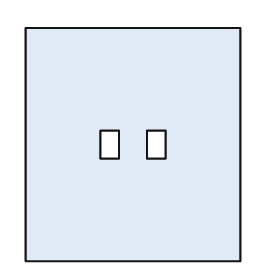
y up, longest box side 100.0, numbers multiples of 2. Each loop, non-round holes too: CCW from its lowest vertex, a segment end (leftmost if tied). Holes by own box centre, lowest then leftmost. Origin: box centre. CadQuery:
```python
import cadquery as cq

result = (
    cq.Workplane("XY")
    .moveTo(-46.0, -50.0)
    .lineTo(46.0, -50.0)
    .lineTo(46.0, 50.0)
    .lineTo(-46.0, 50.0)
    .close()
    .moveTo(-14.0, -6.0)
    .lineTo(-6.0, -6.0)
    .lineTo(-6.0, 6.0)
    .lineTo(-14.0, 6.0)
    .close()
    .moveTo(6.0, -6.0)
    .lineTo(14.0, -6.0)
    .lineTo(14.0, 6.0)
    .lineTo(6.0, 6.0)
    .close()
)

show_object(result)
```